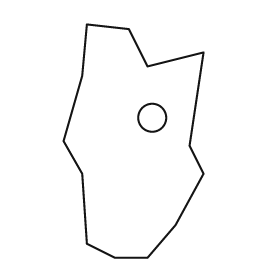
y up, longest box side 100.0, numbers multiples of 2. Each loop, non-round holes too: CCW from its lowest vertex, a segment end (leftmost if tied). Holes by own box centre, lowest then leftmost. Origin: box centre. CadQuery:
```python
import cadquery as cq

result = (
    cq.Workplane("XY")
    .moveTo(-8.0, -50.0)
    .lineTo(6.0, -50.0)
    .lineTo(18.0, -36.0)
    .lineTo(30.0, -14.0)
    .lineTo(24.0, -2.0)
    .lineTo(30.0, 38.0)
    .lineTo(6.0, 32.0)
    .lineTo(-2.0, 48.0)
    .lineTo(-20.0, 50.0)
    .lineTo(-22.0, 28.0)
    .lineTo(-30.0, 0.0)
    .lineTo(-22.0, -14.0)
    .lineTo(-20.0, -44.0)
    .close()
    .moveTo(8.0, 10.0)
    .circle(6.0)
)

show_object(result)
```